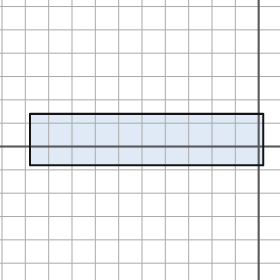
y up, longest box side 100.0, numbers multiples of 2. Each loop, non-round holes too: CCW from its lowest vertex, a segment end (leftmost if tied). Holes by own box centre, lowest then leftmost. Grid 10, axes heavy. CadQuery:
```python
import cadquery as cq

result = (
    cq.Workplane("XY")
    .moveTo(-98.0, -8.0)
    .lineTo(2.0, -8.0)
    .lineTo(2.0, 14.0)
    .lineTo(-98.0, 14.0)
    .close()
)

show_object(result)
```